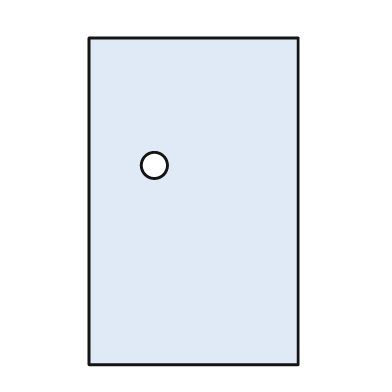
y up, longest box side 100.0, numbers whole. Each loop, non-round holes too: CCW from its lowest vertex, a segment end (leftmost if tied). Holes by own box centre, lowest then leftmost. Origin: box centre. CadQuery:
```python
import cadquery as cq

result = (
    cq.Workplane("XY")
    .moveTo(-32.0, -50.0)
    .lineTo(32.0, -50.0)
    .lineTo(32.0, 50.0)
    .lineTo(-32.0, 50.0)
    .close()
    .moveTo(-12.0, 11.0)
    .circle(4.0)
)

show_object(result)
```